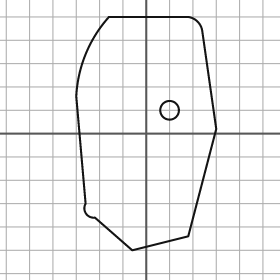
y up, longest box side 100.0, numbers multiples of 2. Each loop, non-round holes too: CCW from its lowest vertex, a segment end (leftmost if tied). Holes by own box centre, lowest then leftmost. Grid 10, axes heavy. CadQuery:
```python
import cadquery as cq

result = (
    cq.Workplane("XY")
    .moveTo(-6.0, -50.0)
    .lineTo(18.0, -44.0)
    .lineTo(30.0, 2.0)
    .lineTo(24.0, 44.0)
    .threePointArc((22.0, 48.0), (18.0, 50.0))
    .lineTo(-16.0, 50.0)
    .threePointArc((-26.0, 34.0), (-30.0, 16.0))
    .lineTo(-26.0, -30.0)
    .threePointArc((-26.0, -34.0), (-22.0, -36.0))
    .close()
    .moveTo(10.0, 10.0)
    .circle(4.0)
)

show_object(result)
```